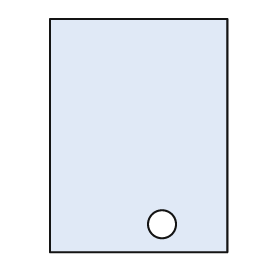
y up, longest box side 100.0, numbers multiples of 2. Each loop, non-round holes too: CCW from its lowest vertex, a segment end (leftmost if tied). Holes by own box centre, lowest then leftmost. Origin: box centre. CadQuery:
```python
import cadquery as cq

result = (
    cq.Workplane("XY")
    .moveTo(-38.0, -50.0)
    .lineTo(38.0, -50.0)
    .lineTo(38.0, 50.0)
    .lineTo(-38.0, 50.0)
    .close()
    .moveTo(10.0, -38.0)
    .circle(6.0)
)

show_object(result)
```